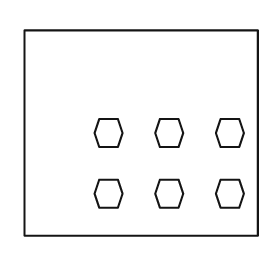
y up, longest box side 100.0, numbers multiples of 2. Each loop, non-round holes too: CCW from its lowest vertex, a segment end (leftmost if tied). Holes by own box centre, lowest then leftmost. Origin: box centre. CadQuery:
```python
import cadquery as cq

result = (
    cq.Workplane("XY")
    .moveTo(-50.0, -44.0)
    .lineTo(50.0, -44.0)
    .lineTo(50.0, 44.0)
    .lineTo(-50.0, 44.0)
    .close()
    .moveTo(-18.0, -32.0)
    .lineTo(-10.0, -32.0)
    .lineTo(-8.0, -26.0)
    .lineTo(-10.0, -20.0)
    .lineTo(-18.0, -20.0)
    .lineTo(-20.0, -26.0)
    .close()
    .moveTo(8.0, -32.0)
    .lineTo(16.0, -32.0)
    .lineTo(18.0, -26.0)
    .lineTo(16.0, -20.0)
    .lineTo(8.0, -20.0)
    .lineTo(6.0, -26.0)
    .close()
    .moveTo(34.0, -32.0)
    .lineTo(42.0, -32.0)
    .lineTo(44.0, -26.0)
    .lineTo(42.0, -20.0)
    .lineTo(34.0, -20.0)
    .lineTo(32.0, -26.0)
    .close()
    .moveTo(-18.0, -6.0)
    .lineTo(-10.0, -6.0)
    .lineTo(-8.0, 0.0)
    .lineTo(-10.0, 6.0)
    .lineTo(-18.0, 6.0)
    .lineTo(-20.0, 0.0)
    .close()
    .moveTo(8.0, -6.0)
    .lineTo(16.0, -6.0)
    .lineTo(18.0, 0.0)
    .lineTo(16.0, 6.0)
    .lineTo(8.0, 6.0)
    .lineTo(6.0, 0.0)
    .close()
    .moveTo(34.0, -6.0)
    .lineTo(42.0, -6.0)
    .lineTo(44.0, 0.0)
    .lineTo(42.0, 6.0)
    .lineTo(34.0, 6.0)
    .lineTo(32.0, 0.0)
    .close()
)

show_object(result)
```